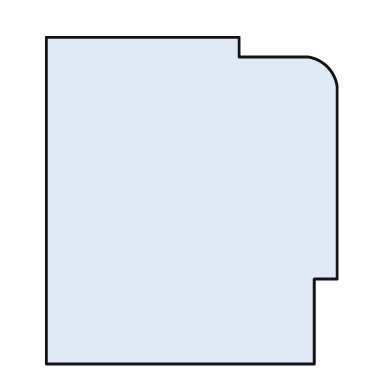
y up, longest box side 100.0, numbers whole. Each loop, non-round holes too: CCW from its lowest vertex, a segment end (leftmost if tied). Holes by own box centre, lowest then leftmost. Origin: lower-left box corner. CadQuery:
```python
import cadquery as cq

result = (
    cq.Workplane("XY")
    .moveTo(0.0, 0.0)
    .lineTo(82.0, 0.0)
    .lineTo(82.0, 26.0)
    .lineTo(89.0, 26.0)
    .lineTo(89.0, 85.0)
    .threePointArc((86.0, 91.0), (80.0, 94.0))
    .lineTo(59.0, 94.0)
    .lineTo(59.0, 100.0)
    .lineTo(0.0, 100.0)
    .close()
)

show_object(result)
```